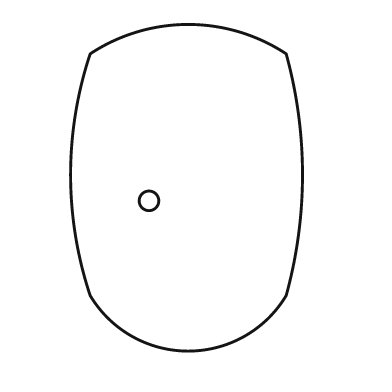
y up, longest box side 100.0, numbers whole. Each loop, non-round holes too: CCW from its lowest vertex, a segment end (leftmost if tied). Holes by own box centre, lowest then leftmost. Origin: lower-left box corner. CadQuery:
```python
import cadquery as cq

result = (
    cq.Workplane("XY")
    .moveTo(6.0, 17.0)
    .threePointArc((36.0, 0.0), (66.0, 17.0))
    .threePointArc((71.0, 54.0), (66.0, 91.0))
    .threePointArc((36.0, 100.0), (6.0, 91.0))
    .threePointArc((0.0, 54.0), (6.0, 17.0))
    .close()
    .moveTo(24.0, 46.0)
    .circle(3.0)
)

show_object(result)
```